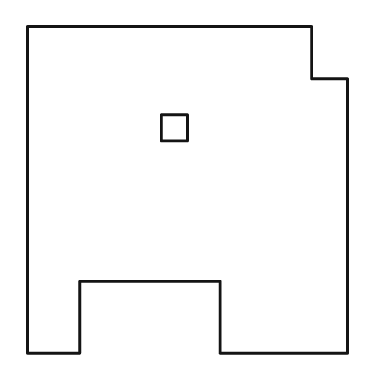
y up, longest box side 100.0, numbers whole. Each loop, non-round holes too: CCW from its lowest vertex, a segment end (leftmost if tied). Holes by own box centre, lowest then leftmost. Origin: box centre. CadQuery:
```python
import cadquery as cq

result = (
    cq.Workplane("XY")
    .moveTo(-49.0, -50.0)
    .lineTo(-33.0, -50.0)
    .lineTo(-33.0, -28.0)
    .lineTo(10.0, -28.0)
    .lineTo(10.0, -50.0)
    .lineTo(49.0, -50.0)
    .lineTo(49.0, 34.0)
    .lineTo(38.0, 34.0)
    .lineTo(38.0, 50.0)
    .lineTo(-49.0, 50.0)
    .close()
    .moveTo(-8.0, 15.0)
    .lineTo(0.0, 15.0)
    .lineTo(0.0, 23.0)
    .lineTo(-8.0, 23.0)
    .close()
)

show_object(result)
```